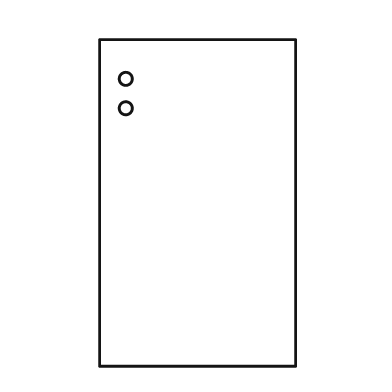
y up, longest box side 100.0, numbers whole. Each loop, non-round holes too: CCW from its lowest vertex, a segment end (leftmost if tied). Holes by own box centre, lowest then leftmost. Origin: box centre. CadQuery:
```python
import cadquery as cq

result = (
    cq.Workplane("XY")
    .moveTo(-30.0, -50.0)
    .lineTo(30.0, -50.0)
    .lineTo(30.0, 50.0)
    .lineTo(-30.0, 50.0)
    .close()
    .moveTo(-22.0, 29.0)
    .circle(2.0)
    .moveTo(-22.0, 38.0)
    .circle(2.0)
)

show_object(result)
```